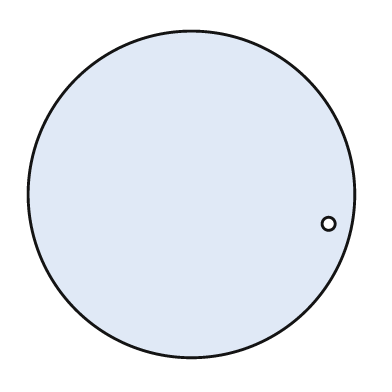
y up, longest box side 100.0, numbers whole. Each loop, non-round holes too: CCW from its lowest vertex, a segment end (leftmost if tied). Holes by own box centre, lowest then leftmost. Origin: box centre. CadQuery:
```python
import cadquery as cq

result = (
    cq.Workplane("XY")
    .moveTo(0.0, 0.0)
    .circle(50.0)
    .moveTo(42.0, -9.0)
    .circle(2.0)
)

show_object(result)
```